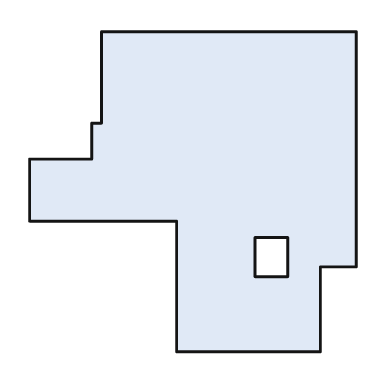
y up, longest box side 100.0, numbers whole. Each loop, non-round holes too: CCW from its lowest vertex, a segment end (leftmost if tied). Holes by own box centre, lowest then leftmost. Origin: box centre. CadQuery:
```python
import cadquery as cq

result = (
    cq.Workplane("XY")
    .moveTo(-5.0, -49.0)
    .lineTo(39.0, -49.0)
    .lineTo(39.0, -23.0)
    .lineTo(50.0, -23.0)
    .lineTo(50.0, 49.0)
    .lineTo(-28.0, 49.0)
    .lineTo(-28.0, 21.0)
    .lineTo(-31.0, 21.0)
    .lineTo(-31.0, 10.0)
    .lineTo(-50.0, 10.0)
    .lineTo(-50.0, -9.0)
    .lineTo(-5.0, -9.0)
    .close()
    .moveTo(19.0, -26.0)
    .lineTo(29.0, -26.0)
    .lineTo(29.0, -14.0)
    .lineTo(19.0, -14.0)
    .close()
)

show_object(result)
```